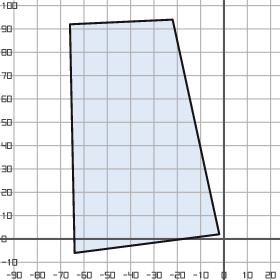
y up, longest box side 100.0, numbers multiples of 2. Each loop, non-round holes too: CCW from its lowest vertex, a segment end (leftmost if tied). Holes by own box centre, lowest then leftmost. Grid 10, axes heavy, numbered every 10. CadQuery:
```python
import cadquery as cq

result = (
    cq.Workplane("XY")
    .moveTo(-64.0, -6.0)
    .lineTo(-2.0, 2.0)
    .lineTo(-22.0, 94.0)
    .lineTo(-66.0, 92.0)
    .close()
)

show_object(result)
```